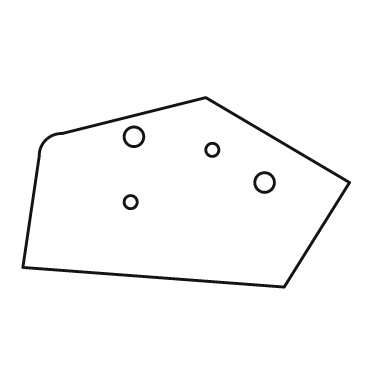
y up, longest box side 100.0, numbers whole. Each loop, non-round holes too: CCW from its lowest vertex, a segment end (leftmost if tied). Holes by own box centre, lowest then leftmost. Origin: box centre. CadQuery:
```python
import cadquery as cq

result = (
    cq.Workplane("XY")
    .moveTo(30.0, -29.0)
    .lineTo(50.0, 3.0)
    .lineTo(6.0, 29.0)
    .lineTo(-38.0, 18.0)
    .threePointArc((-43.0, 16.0), (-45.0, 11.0))
    .lineTo(-50.0, -23.0)
    .close()
    .moveTo(-17.0, -3.0)
    .circle(2.0)
    .moveTo(24.0, 3.0)
    .circle(3.0)
    .moveTo(8.0, 13.0)
    .circle(2.0)
    .moveTo(-16.0, 17.0)
    .circle(3.0)
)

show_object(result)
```